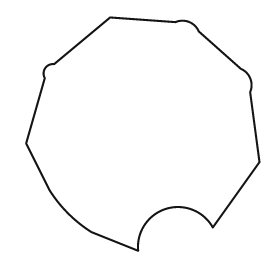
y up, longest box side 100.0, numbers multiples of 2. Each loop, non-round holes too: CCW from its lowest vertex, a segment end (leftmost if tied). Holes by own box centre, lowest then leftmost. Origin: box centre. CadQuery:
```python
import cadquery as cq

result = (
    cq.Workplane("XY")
    .moveTo(-2.0, -50.0)
    .threePointArc((10.0, -32.0), (30.0, -40.0))
    .lineTo(50.0, -12.0)
    .lineTo(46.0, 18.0)
    .threePointArc((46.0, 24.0), (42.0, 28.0))
    .lineTo(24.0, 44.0)
    .threePointArc((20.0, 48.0), (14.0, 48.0))
    .lineTo(-14.0, 50.0)
    .lineTo(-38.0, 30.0)
    .threePointArc((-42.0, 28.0), (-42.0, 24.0))
    .lineTo(-50.0, -4.0)
    .lineTo(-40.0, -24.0)
    .threePointArc((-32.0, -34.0), (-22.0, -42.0))
    .close()
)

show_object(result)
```